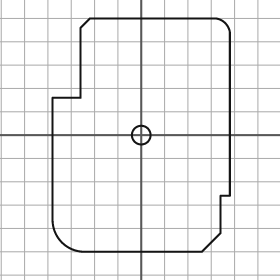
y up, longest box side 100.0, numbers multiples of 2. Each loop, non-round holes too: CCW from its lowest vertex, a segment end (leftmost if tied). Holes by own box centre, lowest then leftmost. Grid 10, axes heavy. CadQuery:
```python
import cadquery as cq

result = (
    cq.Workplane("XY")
    .moveTo(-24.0, -50.0)
    .lineTo(26.0, -50.0)
    .lineTo(34.0, -42.0)
    .lineTo(34.0, -26.0)
    .lineTo(38.0, -26.0)
    .lineTo(38.0, 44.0)
    .threePointArc((36.0, 48.0), (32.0, 50.0))
    .lineTo(-22.0, 50.0)
    .lineTo(-26.0, 46.0)
    .lineTo(-26.0, 16.0)
    .lineTo(-38.0, 16.0)
    .lineTo(-38.0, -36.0)
    .threePointArc((-34.0, -46.0), (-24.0, -50.0))
    .close()
    .moveTo(0.0, 0.0)
    .circle(4.0)
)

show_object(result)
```